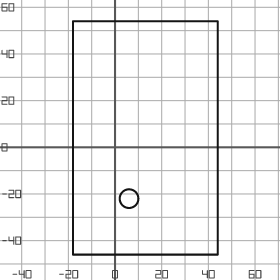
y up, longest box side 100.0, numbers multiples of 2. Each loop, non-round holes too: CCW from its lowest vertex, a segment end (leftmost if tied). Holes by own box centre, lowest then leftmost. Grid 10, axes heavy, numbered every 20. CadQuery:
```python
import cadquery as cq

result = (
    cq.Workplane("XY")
    .moveTo(-18.0, -46.0)
    .lineTo(44.0, -46.0)
    .lineTo(44.0, 54.0)
    .lineTo(-18.0, 54.0)
    .close()
    .moveTo(6.0, -22.0)
    .circle(4.0)
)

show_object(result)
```